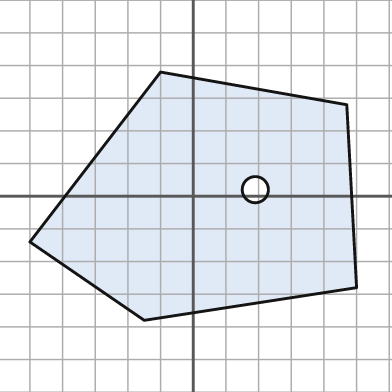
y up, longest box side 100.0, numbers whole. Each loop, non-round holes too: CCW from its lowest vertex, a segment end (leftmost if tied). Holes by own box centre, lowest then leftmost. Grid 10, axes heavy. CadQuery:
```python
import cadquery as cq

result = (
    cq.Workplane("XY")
    .moveTo(-15.0, -38.0)
    .lineTo(50.0, -28.0)
    .lineTo(47.0, 28.0)
    .lineTo(-10.0, 38.0)
    .lineTo(-50.0, -14.0)
    .close()
    .moveTo(19.0, 2.0)
    .circle(4.0)
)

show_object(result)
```